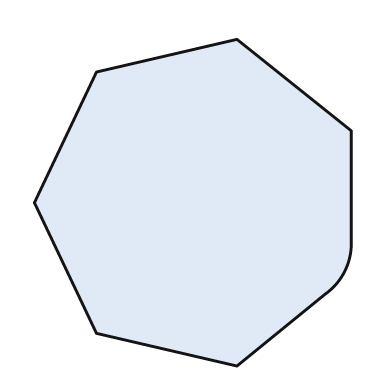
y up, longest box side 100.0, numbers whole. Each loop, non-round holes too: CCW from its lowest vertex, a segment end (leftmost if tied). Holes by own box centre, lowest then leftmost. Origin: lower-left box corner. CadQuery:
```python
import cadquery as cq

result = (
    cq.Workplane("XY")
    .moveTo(62.0, 0.0)
    .lineTo(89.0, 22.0)
    .threePointArc((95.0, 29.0), (97.0, 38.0))
    .lineTo(97.0, 72.0)
    .lineTo(62.0, 100.0)
    .lineTo(19.0, 90.0)
    .lineTo(0.0, 50.0)
    .lineTo(19.0, 10.0)
    .close()
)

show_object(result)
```